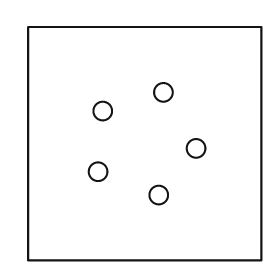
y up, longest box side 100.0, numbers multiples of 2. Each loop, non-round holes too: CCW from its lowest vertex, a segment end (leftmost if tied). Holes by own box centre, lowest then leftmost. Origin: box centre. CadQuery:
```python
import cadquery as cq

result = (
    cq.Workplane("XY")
    .moveTo(-50.0, -50.0)
    .lineTo(50.0, -50.0)
    .lineTo(50.0, 50.0)
    .lineTo(-50.0, 50.0)
    .close()
    .moveTo(6.0, -22.0)
    .circle(4.0)
    .moveTo(-20.0, -12.0)
    .circle(4.0)
    .moveTo(22.0, -2.0)
    .circle(4.0)
    .moveTo(-18.0, 14.0)
    .circle(4.0)
    .moveTo(8.0, 22.0)
    .circle(4.0)
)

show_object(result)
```